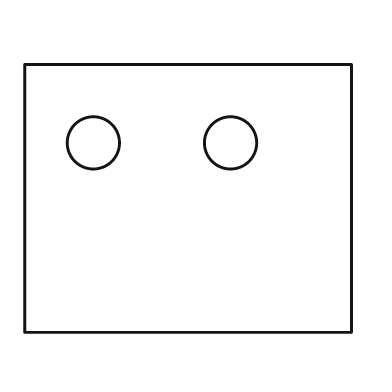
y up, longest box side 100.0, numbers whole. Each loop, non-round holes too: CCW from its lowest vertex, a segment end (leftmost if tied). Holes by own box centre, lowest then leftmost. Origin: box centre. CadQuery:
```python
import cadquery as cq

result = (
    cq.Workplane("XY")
    .moveTo(-50.0, -41.0)
    .lineTo(50.0, -41.0)
    .lineTo(50.0, 41.0)
    .lineTo(-50.0, 41.0)
    .close()
    .moveTo(-29.0, 17.0)
    .circle(8.0)
    .moveTo(13.0, 17.0)
    .circle(8.0)
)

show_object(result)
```